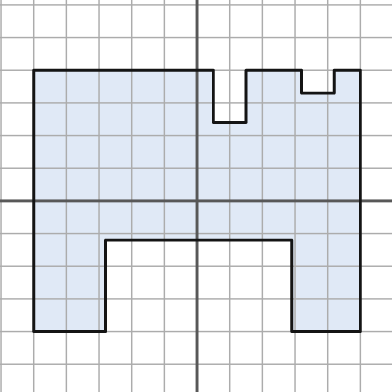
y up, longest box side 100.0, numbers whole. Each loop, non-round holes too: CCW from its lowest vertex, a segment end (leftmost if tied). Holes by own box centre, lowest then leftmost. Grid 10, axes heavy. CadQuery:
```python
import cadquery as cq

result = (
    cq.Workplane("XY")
    .moveTo(-50.0, -40.0)
    .lineTo(-28.0, -40.0)
    .lineTo(-28.0, -12.0)
    .lineTo(29.0, -12.0)
    .lineTo(29.0, -40.0)
    .lineTo(50.0, -40.0)
    .lineTo(50.0, 40.0)
    .lineTo(42.0, 40.0)
    .lineTo(42.0, 33.0)
    .lineTo(32.0, 33.0)
    .lineTo(32.0, 40.0)
    .lineTo(15.0, 40.0)
    .lineTo(15.0, 24.0)
    .lineTo(5.0, 24.0)
    .lineTo(5.0, 40.0)
    .lineTo(-50.0, 40.0)
    .close()
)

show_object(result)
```